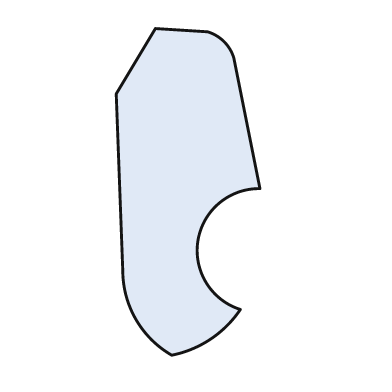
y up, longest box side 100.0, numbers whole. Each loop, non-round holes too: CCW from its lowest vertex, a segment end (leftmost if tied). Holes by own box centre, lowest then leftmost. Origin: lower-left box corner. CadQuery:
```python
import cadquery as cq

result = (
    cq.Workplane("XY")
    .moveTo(17.0, 0.0)
    .threePointArc((29.0, 5.0), (38.0, 14.0))
    .threePointArc((25.0, 35.0), (44.0, 51.0))
    .lineTo(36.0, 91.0)
    .threePointArc((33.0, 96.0), (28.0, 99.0))
    .lineTo(12.0, 100.0)
    .lineTo(0.0, 80.0)
    .lineTo(2.0, 26.0)
    .threePointArc((6.0, 11.0), (17.0, 0.0))
    .close()
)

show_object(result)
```